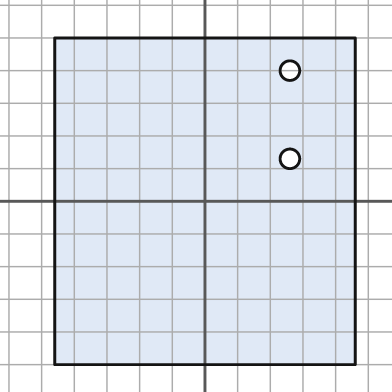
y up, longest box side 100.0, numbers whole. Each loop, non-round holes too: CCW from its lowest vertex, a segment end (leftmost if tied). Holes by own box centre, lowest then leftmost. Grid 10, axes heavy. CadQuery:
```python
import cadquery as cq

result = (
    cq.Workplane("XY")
    .moveTo(-46.0, -50.0)
    .lineTo(46.0, -50.0)
    .lineTo(46.0, 50.0)
    .lineTo(-46.0, 50.0)
    .close()
    .moveTo(26.0, 13.0)
    .circle(3.0)
    .moveTo(26.0, 40.0)
    .circle(3.0)
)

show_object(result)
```